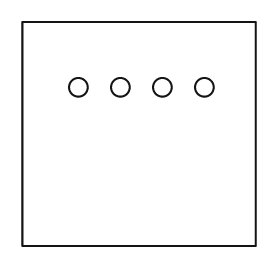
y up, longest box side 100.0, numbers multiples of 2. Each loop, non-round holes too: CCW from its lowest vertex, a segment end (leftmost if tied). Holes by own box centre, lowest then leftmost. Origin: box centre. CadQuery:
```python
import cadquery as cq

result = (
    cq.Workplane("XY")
    .moveTo(-50.0, -48.0)
    .lineTo(50.0, -48.0)
    .lineTo(50.0, 48.0)
    .lineTo(-50.0, 48.0)
    .close()
    .moveTo(-26.0, 20.0)
    .circle(4.0)
    .moveTo(-8.0, 20.0)
    .circle(4.0)
    .moveTo(10.0, 20.0)
    .circle(4.0)
    .moveTo(28.0, 20.0)
    .circle(4.0)
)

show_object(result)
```